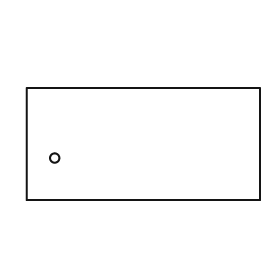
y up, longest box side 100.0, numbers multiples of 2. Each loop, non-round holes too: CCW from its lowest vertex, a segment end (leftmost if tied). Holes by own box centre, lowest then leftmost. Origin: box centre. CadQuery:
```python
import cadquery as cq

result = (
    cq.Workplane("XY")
    .moveTo(-50.0, -24.0)
    .lineTo(50.0, -24.0)
    .lineTo(50.0, 24.0)
    .lineTo(-50.0, 24.0)
    .close()
    .moveTo(-38.0, -6.0)
    .circle(2.0)
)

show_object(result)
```